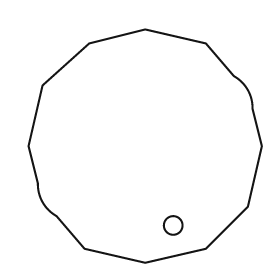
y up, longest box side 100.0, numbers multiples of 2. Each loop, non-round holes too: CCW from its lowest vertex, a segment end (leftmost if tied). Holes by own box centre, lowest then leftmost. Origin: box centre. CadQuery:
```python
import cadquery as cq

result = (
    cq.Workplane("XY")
    .moveTo(0.0, -50.0)
    .lineTo(26.0, -44.0)
    .lineTo(44.0, -26.0)
    .lineTo(50.0, 0.0)
    .lineTo(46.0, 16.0)
    .threePointArc((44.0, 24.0), (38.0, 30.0))
    .lineTo(26.0, 44.0)
    .lineTo(0.0, 50.0)
    .lineTo(-24.0, 44.0)
    .lineTo(-44.0, 26.0)
    .lineTo(-50.0, 0.0)
    .lineTo(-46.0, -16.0)
    .threePointArc((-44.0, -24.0), (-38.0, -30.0))
    .lineTo(-26.0, -44.0)
    .close()
    .moveTo(12.0, -34.0)
    .circle(4.0)
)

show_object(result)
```